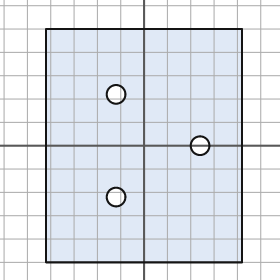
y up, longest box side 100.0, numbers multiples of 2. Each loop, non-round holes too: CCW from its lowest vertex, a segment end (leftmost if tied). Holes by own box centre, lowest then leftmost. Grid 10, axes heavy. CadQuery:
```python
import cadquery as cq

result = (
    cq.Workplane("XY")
    .moveTo(-42.0, -50.0)
    .lineTo(42.0, -50.0)
    .lineTo(42.0, 50.0)
    .lineTo(-42.0, 50.0)
    .close()
    .moveTo(-12.0, -22.0)
    .circle(4.0)
    .moveTo(24.0, 0.0)
    .circle(4.0)
    .moveTo(-12.0, 22.0)
    .circle(4.0)
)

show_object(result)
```